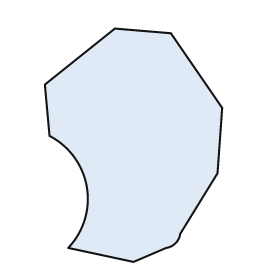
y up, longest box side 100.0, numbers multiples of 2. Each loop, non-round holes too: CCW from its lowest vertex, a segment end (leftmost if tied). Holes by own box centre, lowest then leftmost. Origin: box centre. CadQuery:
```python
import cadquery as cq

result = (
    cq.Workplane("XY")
    .moveTo(0.0, -50.0)
    .lineTo(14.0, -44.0)
    .threePointArc((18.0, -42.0), (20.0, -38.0))
    .lineTo(36.0, -12.0)
    .lineTo(38.0, 16.0)
    .lineTo(16.0, 48.0)
    .lineTo(-8.0, 50.0)
    .lineTo(-38.0, 26.0)
    .lineTo(-36.0, 4.0)
    .threePointArc((-20.0, -18.0), (-28.0, -44.0))
    .close()
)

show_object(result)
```